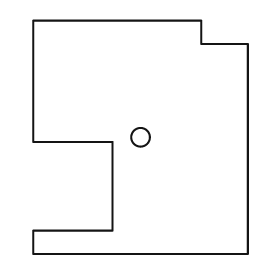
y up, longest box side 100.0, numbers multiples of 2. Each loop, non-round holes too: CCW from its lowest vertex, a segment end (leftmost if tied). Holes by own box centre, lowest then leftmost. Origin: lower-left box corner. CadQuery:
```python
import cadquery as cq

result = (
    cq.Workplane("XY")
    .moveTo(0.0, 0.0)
    .lineTo(92.0, 0.0)
    .lineTo(92.0, 90.0)
    .lineTo(72.0, 90.0)
    .lineTo(72.0, 100.0)
    .lineTo(0.0, 100.0)
    .lineTo(0.0, 48.0)
    .lineTo(34.0, 48.0)
    .lineTo(34.0, 10.0)
    .lineTo(0.0, 10.0)
    .close()
    .moveTo(46.0, 50.0)
    .circle(4.0)
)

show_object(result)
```